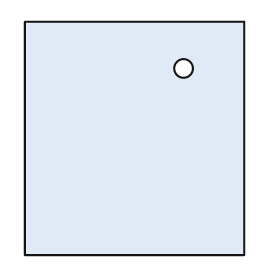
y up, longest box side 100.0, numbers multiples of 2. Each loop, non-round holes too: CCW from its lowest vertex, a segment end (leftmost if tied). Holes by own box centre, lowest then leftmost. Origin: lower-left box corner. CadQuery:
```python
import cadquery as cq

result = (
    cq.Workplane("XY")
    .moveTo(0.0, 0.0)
    .lineTo(94.0, 0.0)
    .lineTo(94.0, 100.0)
    .lineTo(0.0, 100.0)
    .close()
    .moveTo(68.0, 80.0)
    .circle(4.0)
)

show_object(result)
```